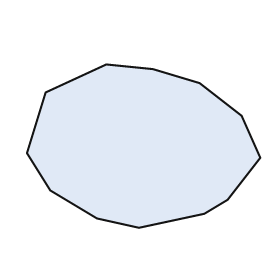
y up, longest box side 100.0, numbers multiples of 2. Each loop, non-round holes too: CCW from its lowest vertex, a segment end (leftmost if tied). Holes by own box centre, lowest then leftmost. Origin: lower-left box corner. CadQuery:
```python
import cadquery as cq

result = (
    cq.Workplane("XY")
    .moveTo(48.0, 0.0)
    .lineTo(76.0, 6.0)
    .lineTo(86.0, 12.0)
    .lineTo(100.0, 30.0)
    .lineTo(92.0, 48.0)
    .lineTo(74.0, 62.0)
    .lineTo(54.0, 68.0)
    .lineTo(34.0, 70.0)
    .lineTo(8.0, 58.0)
    .lineTo(0.0, 32.0)
    .lineTo(10.0, 16.0)
    .lineTo(30.0, 4.0)
    .close()
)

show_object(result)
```